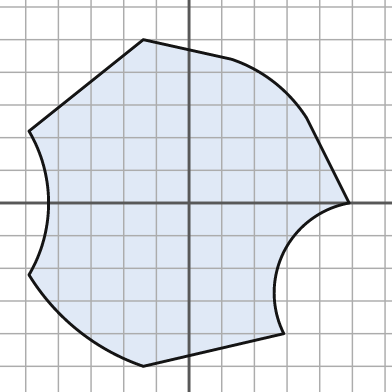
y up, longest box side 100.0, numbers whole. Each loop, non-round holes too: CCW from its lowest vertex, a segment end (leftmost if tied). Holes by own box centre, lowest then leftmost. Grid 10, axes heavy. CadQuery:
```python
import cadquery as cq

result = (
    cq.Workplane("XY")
    .moveTo(-14.0, -50.0)
    .lineTo(29.0, -40.0)
    .threePointArc((29.0, -15.0), (49.0, 0.0))
    .lineTo(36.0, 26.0)
    .threePointArc((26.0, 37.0), (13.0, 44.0))
    .lineTo(-14.0, 50.0)
    .lineTo(-49.0, 22.0)
    .threePointArc((-43.0, 0.0), (-49.0, -22.0))
    .threePointArc((-34.0, -39.0), (-14.0, -50.0))
    .close()
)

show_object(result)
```